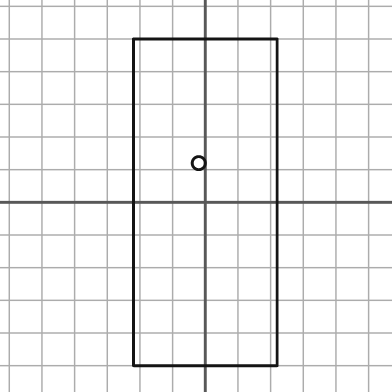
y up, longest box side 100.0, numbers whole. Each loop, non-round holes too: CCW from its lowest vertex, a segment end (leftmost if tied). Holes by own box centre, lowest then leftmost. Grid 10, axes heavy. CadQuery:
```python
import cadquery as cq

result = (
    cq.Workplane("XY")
    .moveTo(-22.0, -50.0)
    .lineTo(22.0, -50.0)
    .lineTo(22.0, 50.0)
    .lineTo(-22.0, 50.0)
    .close()
    .moveTo(-2.0, 12.0)
    .circle(2.0)
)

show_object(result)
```